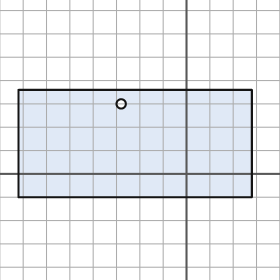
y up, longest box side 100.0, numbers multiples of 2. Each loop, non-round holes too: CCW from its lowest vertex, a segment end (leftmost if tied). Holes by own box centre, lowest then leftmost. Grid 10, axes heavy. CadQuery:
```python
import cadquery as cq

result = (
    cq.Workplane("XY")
    .moveTo(-72.0, -10.0)
    .lineTo(28.0, -10.0)
    .lineTo(28.0, 36.0)
    .lineTo(-72.0, 36.0)
    .close()
    .moveTo(-28.0, 30.0)
    .circle(2.0)
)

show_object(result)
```